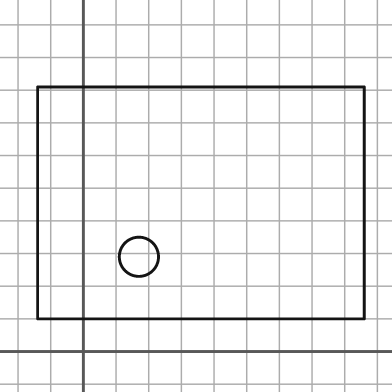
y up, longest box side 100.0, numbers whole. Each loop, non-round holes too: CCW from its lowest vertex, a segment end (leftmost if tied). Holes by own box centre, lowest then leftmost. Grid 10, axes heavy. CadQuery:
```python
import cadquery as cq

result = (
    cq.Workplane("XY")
    .moveTo(-14.0, 10.0)
    .lineTo(86.0, 10.0)
    .lineTo(86.0, 81.0)
    .lineTo(-14.0, 81.0)
    .close()
    .moveTo(17.0, 29.0)
    .circle(6.0)
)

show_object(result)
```